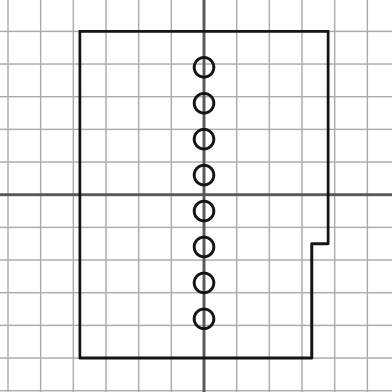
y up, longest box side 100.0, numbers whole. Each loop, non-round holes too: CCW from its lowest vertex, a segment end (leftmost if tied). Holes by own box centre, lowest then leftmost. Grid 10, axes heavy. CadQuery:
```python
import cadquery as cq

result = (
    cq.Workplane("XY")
    .moveTo(-38.0, -50.0)
    .lineTo(33.0, -50.0)
    .lineTo(33.0, -15.0)
    .lineTo(38.0, -15.0)
    .lineTo(38.0, 50.0)
    .lineTo(-38.0, 50.0)
    .close()
    .moveTo(0.0, -38.0)
    .circle(3.0)
    .moveTo(0.0, -27.0)
    .circle(3.0)
    .moveTo(0.0, -16.0)
    .circle(3.0)
    .moveTo(0.0, -5.0)
    .circle(3.0)
    .moveTo(0.0, 6.0)
    .circle(3.0)
    .moveTo(0.0, 17.0)
    .circle(3.0)
    .moveTo(0.0, 28.0)
    .circle(3.0)
    .moveTo(0.0, 39.0)
    .circle(3.0)
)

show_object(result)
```